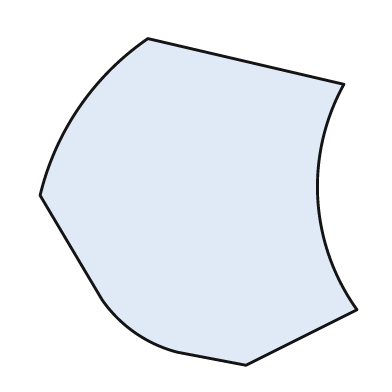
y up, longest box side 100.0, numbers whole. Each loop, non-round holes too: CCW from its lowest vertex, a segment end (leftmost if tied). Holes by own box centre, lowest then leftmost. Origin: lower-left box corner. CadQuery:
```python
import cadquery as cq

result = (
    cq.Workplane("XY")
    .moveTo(63.0, 0.0)
    .lineTo(97.0, 17.0)
    .threePointArc((85.0, 51.0), (93.0, 86.0))
    .lineTo(33.0, 100.0)
    .threePointArc((12.0, 79.0), (0.0, 52.0))
    .lineTo(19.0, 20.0)
    .threePointArc((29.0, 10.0), (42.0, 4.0))
    .close()
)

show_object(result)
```